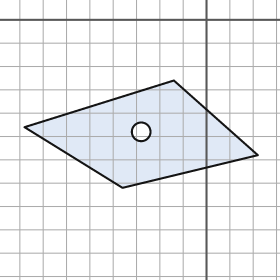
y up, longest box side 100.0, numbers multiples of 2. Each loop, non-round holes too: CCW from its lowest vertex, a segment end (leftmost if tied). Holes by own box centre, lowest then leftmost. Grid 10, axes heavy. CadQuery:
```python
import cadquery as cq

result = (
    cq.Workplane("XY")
    .moveTo(-36.0, -72.0)
    .lineTo(22.0, -58.0)
    .lineTo(-14.0, -26.0)
    .lineTo(-78.0, -46.0)
    .close()
    .moveTo(-28.0, -48.0)
    .circle(4.0)
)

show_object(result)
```